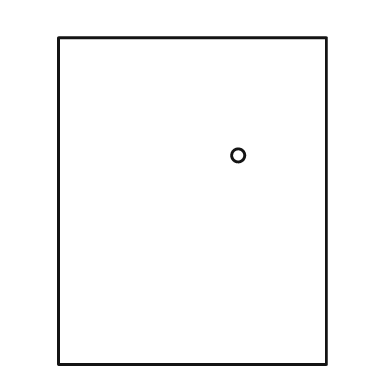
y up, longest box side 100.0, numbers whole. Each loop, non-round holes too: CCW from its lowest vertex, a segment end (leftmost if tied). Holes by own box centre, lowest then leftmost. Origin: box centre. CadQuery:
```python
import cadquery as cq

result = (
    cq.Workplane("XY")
    .moveTo(-41.0, -50.0)
    .lineTo(41.0, -50.0)
    .lineTo(41.0, 50.0)
    .lineTo(-41.0, 50.0)
    .close()
    .moveTo(14.0, 14.0)
    .circle(2.0)
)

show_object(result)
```